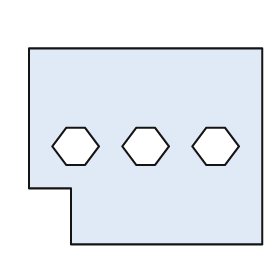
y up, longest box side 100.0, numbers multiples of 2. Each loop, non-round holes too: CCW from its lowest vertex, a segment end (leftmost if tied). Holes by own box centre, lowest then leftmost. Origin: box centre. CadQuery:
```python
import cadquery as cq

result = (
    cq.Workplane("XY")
    .moveTo(-32.0, -42.0)
    .lineTo(50.0, -42.0)
    .lineTo(50.0, 42.0)
    .lineTo(-50.0, 42.0)
    .lineTo(-50.0, -18.0)
    .lineTo(-32.0, -18.0)
    .close()
    .moveTo(-34.0, -8.0)
    .lineTo(-26.0, -8.0)
    .lineTo(-20.0, 0.0)
    .lineTo(-26.0, 8.0)
    .lineTo(-34.0, 8.0)
    .lineTo(-40.0, 0.0)
    .close()
    .moveTo(-4.0, -8.0)
    .lineTo(4.0, -8.0)
    .lineTo(10.0, 0.0)
    .lineTo(4.0, 8.0)
    .lineTo(-4.0, 8.0)
    .lineTo(-10.0, 0.0)
    .close()
    .moveTo(26.0, -8.0)
    .lineTo(34.0, -8.0)
    .lineTo(40.0, 0.0)
    .lineTo(34.0, 8.0)
    .lineTo(26.0, 8.0)
    .lineTo(20.0, 0.0)
    .close()
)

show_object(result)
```